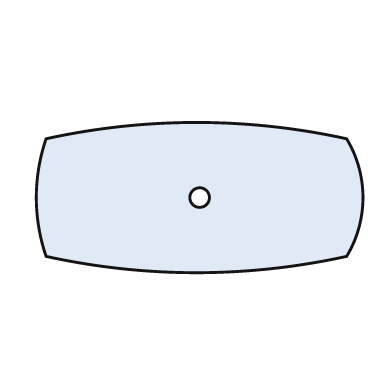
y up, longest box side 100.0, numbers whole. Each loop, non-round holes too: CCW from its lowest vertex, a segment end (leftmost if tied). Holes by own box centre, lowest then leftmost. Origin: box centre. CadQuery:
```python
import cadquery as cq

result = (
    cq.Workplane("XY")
    .moveTo(-47.0, -18.0)
    .threePointArc((-1.0, -23.0), (45.0, -18.0))
    .threePointArc((50.0, 0.0), (45.0, 18.0))
    .threePointArc((-1.0, 23.0), (-47.0, 18.0))
    .threePointArc((-50.0, 0.0), (-47.0, -18.0))
    .close()
    .moveTo(0.0, 0.0)
    .circle(3.0)
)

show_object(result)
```